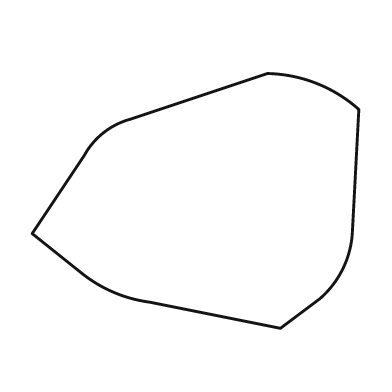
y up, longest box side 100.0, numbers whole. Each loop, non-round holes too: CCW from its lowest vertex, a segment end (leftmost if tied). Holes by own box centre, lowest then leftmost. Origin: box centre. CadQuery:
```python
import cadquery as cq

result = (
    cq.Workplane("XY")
    .moveTo(26.0, -39.0)
    .lineTo(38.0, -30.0)
    .threePointArc((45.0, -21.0), (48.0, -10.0))
    .lineTo(50.0, 28.0)
    .threePointArc((37.0, 36.0), (22.0, 39.0))
    .lineTo(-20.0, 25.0)
    .threePointArc((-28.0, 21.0), (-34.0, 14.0))
    .lineTo(-50.0, -10.0)
    .lineTo(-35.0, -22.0)
    .threePointArc((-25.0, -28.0), (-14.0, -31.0))
    .close()
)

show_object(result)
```